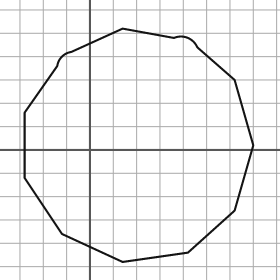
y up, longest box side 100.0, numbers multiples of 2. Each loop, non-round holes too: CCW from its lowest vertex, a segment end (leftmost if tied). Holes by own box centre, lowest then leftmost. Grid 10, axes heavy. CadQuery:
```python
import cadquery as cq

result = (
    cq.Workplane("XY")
    .moveTo(14.0, -48.0)
    .lineTo(42.0, -44.0)
    .lineTo(62.0, -26.0)
    .lineTo(70.0, 2.0)
    .lineTo(62.0, 30.0)
    .lineTo(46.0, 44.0)
    .threePointArc((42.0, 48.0), (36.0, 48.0))
    .lineTo(14.0, 52.0)
    .lineTo(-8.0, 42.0)
    .threePointArc((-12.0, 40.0), (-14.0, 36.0))
    .lineTo(-28.0, 16.0)
    .lineTo(-28.0, -12.0)
    .lineTo(-12.0, -36.0)
    .close()
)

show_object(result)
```